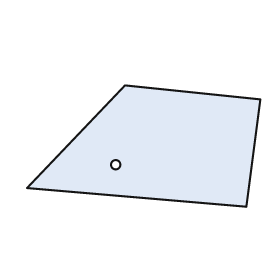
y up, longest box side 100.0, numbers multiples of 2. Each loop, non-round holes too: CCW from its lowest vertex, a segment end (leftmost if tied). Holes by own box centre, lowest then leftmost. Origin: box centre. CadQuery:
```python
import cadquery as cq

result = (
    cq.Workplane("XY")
    .moveTo(44.0, -26.0)
    .lineTo(50.0, 20.0)
    .lineTo(-8.0, 26.0)
    .lineTo(-50.0, -18.0)
    .close()
    .moveTo(-12.0, -8.0)
    .circle(2.0)
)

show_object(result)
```